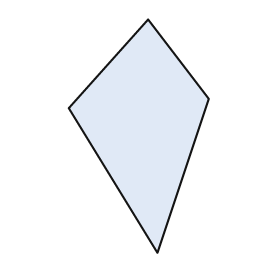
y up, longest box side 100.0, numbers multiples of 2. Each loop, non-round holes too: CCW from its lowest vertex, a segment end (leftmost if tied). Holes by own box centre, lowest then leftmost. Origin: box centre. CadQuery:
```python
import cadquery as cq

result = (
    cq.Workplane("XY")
    .moveTo(8.0, -50.0)
    .lineTo(30.0, 16.0)
    .lineTo(4.0, 50.0)
    .lineTo(-30.0, 12.0)
    .close()
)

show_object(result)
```